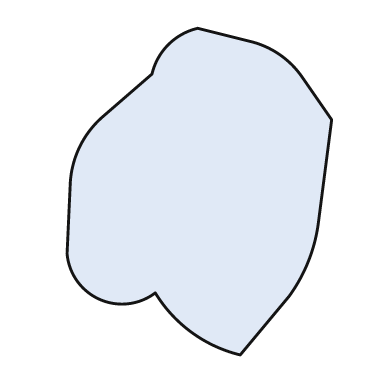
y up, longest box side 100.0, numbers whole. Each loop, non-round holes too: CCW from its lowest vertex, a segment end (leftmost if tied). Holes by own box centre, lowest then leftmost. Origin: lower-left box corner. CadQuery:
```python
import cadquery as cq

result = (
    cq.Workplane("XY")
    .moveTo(53.0, 0.0)
    .lineTo(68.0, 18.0)
    .threePointArc((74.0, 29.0), (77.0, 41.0))
    .lineTo(81.0, 72.0)
    .lineTo(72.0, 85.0)
    .threePointArc((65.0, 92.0), (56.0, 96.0))
    .lineTo(40.0, 100.0)
    .threePointArc((31.0, 95.0), (26.0, 86.0))
    .lineTo(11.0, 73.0)
    .threePointArc((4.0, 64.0), (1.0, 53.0))
    .lineTo(0.0, 31.0)
    .threePointArc((10.0, 17.0), (27.0, 19.0))
    .threePointArc((38.0, 7.0), (53.0, 0.0))
    .close()
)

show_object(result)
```